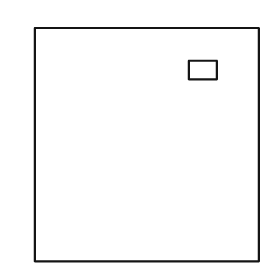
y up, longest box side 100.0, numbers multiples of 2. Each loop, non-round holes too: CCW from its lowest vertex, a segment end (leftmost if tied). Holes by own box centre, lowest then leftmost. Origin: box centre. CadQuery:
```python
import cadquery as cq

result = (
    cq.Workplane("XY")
    .moveTo(-48.0, -50.0)
    .lineTo(48.0, -50.0)
    .lineTo(48.0, 50.0)
    .lineTo(-48.0, 50.0)
    .close()
    .moveTo(18.0, 28.0)
    .lineTo(30.0, 28.0)
    .lineTo(30.0, 36.0)
    .lineTo(18.0, 36.0)
    .close()
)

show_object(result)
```